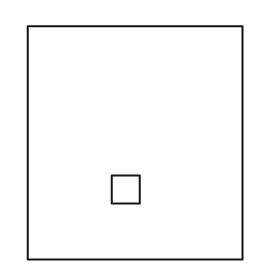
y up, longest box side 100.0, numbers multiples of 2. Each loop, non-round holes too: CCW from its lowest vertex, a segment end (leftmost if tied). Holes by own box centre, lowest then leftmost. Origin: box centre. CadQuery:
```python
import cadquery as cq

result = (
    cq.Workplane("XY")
    .moveTo(-46.0, -50.0)
    .lineTo(46.0, -50.0)
    .lineTo(46.0, 50.0)
    .lineTo(-46.0, 50.0)
    .close()
    .moveTo(-10.0, -26.0)
    .lineTo(2.0, -26.0)
    .lineTo(2.0, -14.0)
    .lineTo(-10.0, -14.0)
    .close()
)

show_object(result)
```